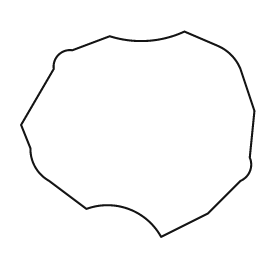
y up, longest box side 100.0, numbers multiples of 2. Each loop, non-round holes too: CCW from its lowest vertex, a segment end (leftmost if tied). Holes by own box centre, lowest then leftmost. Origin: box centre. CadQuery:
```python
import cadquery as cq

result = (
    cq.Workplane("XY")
    .moveTo(10.0, -44.0)
    .lineTo(30.0, -34.0)
    .lineTo(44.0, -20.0)
    .threePointArc((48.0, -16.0), (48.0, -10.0))
    .lineTo(50.0, 10.0)
    .lineTo(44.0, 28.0)
    .threePointArc((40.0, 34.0), (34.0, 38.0))
    .lineTo(20.0, 44.0)
    .threePointArc((4.0, 40.0), (-12.0, 42.0))
    .lineTo(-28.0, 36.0)
    .threePointArc((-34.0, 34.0), (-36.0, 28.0))
    .lineTo(-50.0, 4.0)
    .lineTo(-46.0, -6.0)
    .threePointArc((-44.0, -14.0), (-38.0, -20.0))
    .lineTo(-22.0, -32.0)
    .threePointArc((-4.0, -32.0), (10.0, -44.0))
    .close()
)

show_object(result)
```